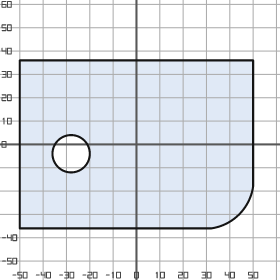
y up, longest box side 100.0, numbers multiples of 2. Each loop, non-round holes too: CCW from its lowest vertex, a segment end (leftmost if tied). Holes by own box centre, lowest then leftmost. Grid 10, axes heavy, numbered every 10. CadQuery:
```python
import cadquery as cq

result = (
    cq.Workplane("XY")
    .moveTo(-50.0, -36.0)
    .lineTo(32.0, -36.0)
    .threePointArc((44.0, -30.0), (50.0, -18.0))
    .lineTo(50.0, 36.0)
    .lineTo(-50.0, 36.0)
    .close()
    .moveTo(-28.0, -4.0)
    .circle(8.0)
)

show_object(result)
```